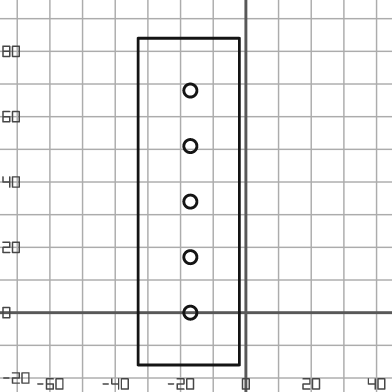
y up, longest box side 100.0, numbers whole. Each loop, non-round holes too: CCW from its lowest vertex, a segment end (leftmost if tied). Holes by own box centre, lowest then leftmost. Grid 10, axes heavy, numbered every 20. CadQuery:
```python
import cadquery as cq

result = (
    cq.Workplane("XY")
    .moveTo(-33.0, -16.0)
    .lineTo(-2.0, -16.0)
    .lineTo(-2.0, 84.0)
    .lineTo(-33.0, 84.0)
    .close()
    .moveTo(-17.0, 0.0)
    .circle(2.0)
    .moveTo(-17.0, 17.0)
    .circle(2.0)
    .moveTo(-17.0, 34.0)
    .circle(2.0)
    .moveTo(-17.0, 51.0)
    .circle(2.0)
    .moveTo(-17.0, 68.0)
    .circle(2.0)
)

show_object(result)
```